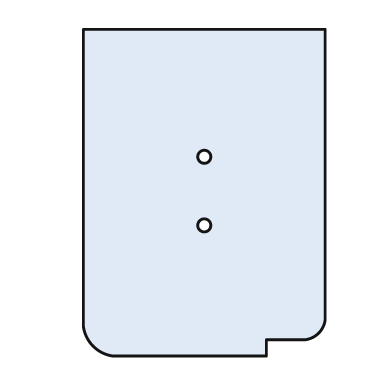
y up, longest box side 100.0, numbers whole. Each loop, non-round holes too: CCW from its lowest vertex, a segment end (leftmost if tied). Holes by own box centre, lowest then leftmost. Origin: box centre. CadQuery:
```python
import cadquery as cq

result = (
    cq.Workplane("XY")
    .moveTo(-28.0, -50.0)
    .lineTo(19.0, -50.0)
    .lineTo(19.0, -45.0)
    .lineTo(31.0, -45.0)
    .threePointArc((35.0, -43.0), (37.0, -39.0))
    .lineTo(37.0, 50.0)
    .lineTo(-37.0, 50.0)
    .lineTo(-37.0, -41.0)
    .threePointArc((-34.0, -47.0), (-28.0, -50.0))
    .close()
    .moveTo(0.0, -10.0)
    .circle(2.0)
    .moveTo(0.0, 11.0)
    .circle(2.0)
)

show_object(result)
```